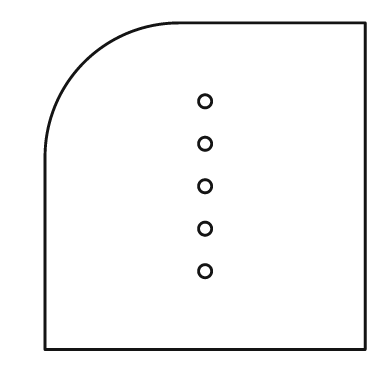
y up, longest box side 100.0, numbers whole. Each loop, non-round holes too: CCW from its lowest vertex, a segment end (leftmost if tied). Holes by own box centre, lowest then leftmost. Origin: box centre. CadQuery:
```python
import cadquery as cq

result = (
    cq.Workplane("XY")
    .moveTo(-49.0, -50.0)
    .lineTo(49.0, -50.0)
    .lineTo(49.0, 50.0)
    .lineTo(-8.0, 50.0)
    .threePointArc((-37.0, 38.0), (-49.0, 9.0))
    .close()
    .moveTo(0.0, -26.0)
    .circle(2.0)
    .moveTo(0.0, -13.0)
    .circle(2.0)
    .moveTo(0.0, 0.0)
    .circle(2.0)
    .moveTo(0.0, 13.0)
    .circle(2.0)
    .moveTo(0.0, 26.0)
    .circle(2.0)
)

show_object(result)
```